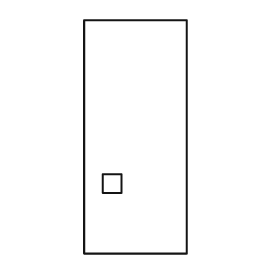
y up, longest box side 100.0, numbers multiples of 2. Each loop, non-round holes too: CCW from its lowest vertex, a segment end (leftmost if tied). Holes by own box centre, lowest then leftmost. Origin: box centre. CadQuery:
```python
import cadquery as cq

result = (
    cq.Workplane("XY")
    .moveTo(-22.0, -50.0)
    .lineTo(22.0, -50.0)
    .lineTo(22.0, 50.0)
    .lineTo(-22.0, 50.0)
    .close()
    .moveTo(-14.0, -24.0)
    .lineTo(-6.0, -24.0)
    .lineTo(-6.0, -16.0)
    .lineTo(-14.0, -16.0)
    .close()
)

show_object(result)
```